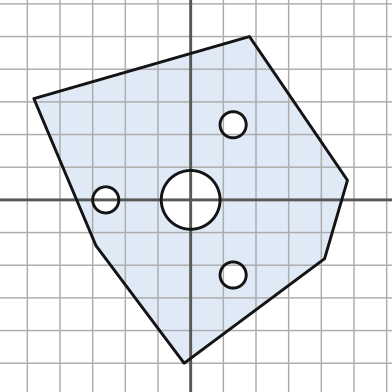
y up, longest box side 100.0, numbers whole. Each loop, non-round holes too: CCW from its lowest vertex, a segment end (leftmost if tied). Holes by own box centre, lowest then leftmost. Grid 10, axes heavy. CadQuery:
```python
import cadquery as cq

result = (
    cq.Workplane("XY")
    .moveTo(-2.0, -50.0)
    .lineTo(41.0, -18.0)
    .lineTo(48.0, 6.0)
    .lineTo(18.0, 50.0)
    .lineTo(-48.0, 31.0)
    .lineTo(-29.0, -14.0)
    .close()
    .moveTo(13.0, -23.0)
    .circle(4.0)
    .moveTo(-26.0, 0.0)
    .circle(4.0)
    .moveTo(0.0, 0.0)
    .circle(9.0)
    .moveTo(13.0, 23.0)
    .circle(4.0)
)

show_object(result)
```